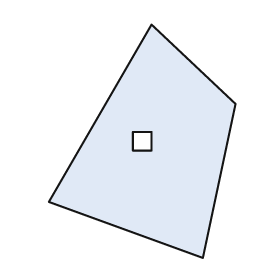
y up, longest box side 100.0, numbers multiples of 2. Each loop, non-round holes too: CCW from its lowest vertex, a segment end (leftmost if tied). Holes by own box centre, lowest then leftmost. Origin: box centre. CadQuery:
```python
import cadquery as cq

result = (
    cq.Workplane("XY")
    .moveTo(26.0, -50.0)
    .lineTo(40.0, 16.0)
    .lineTo(4.0, 50.0)
    .lineTo(-40.0, -26.0)
    .close()
    .moveTo(-4.0, -4.0)
    .lineTo(4.0, -4.0)
    .lineTo(4.0, 4.0)
    .lineTo(-4.0, 4.0)
    .close()
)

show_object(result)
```